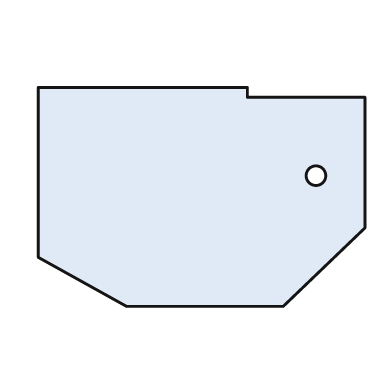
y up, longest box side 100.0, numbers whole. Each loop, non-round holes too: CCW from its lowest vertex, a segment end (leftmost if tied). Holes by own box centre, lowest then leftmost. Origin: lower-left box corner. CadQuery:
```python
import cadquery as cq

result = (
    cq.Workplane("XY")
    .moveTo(27.0, 0.0)
    .lineTo(75.0, 0.0)
    .lineTo(100.0, 24.0)
    .lineTo(100.0, 64.0)
    .lineTo(64.0, 64.0)
    .lineTo(64.0, 67.0)
    .lineTo(0.0, 67.0)
    .lineTo(0.0, 15.0)
    .close()
    .moveTo(85.0, 40.0)
    .circle(3.0)
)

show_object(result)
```